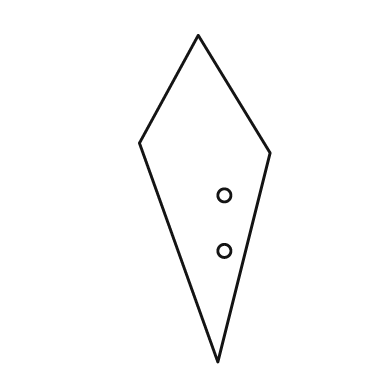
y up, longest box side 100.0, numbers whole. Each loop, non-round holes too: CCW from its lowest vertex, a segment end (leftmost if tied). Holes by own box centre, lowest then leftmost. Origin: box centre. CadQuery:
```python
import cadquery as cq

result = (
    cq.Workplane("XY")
    .moveTo(4.0, -50.0)
    .lineTo(20.0, 14.0)
    .lineTo(-2.0, 50.0)
    .lineTo(-20.0, 17.0)
    .close()
    .moveTo(6.0, -16.0)
    .circle(2.0)
    .moveTo(6.0, 1.0)
    .circle(2.0)
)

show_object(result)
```